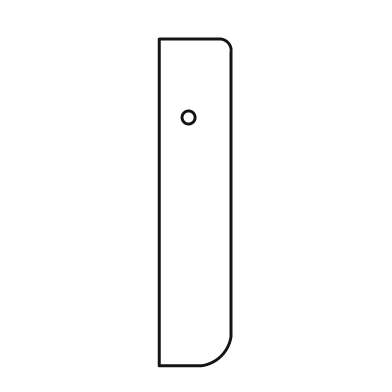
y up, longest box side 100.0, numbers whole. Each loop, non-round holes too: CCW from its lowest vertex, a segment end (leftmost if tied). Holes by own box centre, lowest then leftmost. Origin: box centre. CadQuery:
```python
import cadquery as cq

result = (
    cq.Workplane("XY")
    .moveTo(-11.0, -50.0)
    .lineTo(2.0, -50.0)
    .threePointArc((8.0, -47.0), (11.0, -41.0))
    .lineTo(11.0, 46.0)
    .threePointArc((10.0, 49.0), (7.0, 50.0))
    .lineTo(-11.0, 50.0)
    .close()
    .moveTo(-2.0, 26.0)
    .circle(2.0)
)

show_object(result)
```